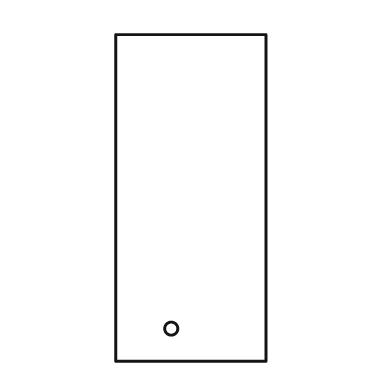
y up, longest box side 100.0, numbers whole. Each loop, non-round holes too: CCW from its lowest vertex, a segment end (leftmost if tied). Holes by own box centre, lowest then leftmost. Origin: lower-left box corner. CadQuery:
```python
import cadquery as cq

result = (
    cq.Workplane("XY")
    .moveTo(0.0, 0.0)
    .lineTo(46.0, 0.0)
    .lineTo(46.0, 100.0)
    .lineTo(0.0, 100.0)
    .close()
    .moveTo(17.0, 10.0)
    .circle(2.0)
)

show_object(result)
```